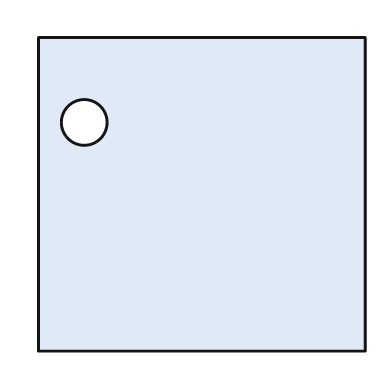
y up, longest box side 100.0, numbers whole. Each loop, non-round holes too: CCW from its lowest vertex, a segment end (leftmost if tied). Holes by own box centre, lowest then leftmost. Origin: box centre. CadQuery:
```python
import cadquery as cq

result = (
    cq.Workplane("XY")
    .moveTo(-50.0, -48.0)
    .lineTo(50.0, -48.0)
    .lineTo(50.0, 48.0)
    .lineTo(-50.0, 48.0)
    .close()
    .moveTo(-36.0, 22.0)
    .circle(7.0)
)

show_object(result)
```